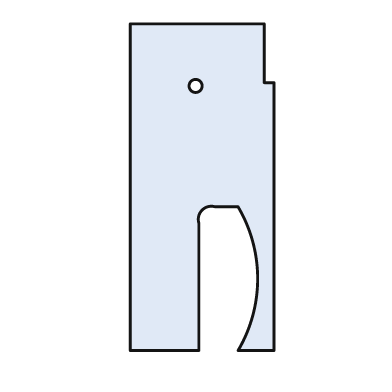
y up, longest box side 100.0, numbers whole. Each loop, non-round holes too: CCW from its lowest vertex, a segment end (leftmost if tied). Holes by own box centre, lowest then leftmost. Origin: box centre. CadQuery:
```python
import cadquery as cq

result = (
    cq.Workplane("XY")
    .moveTo(-22.0, -50.0)
    .lineTo(-1.0, -50.0)
    .lineTo(-1.0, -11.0)
    .threePointArc((0.0, -7.0), (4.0, -6.0))
    .lineTo(11.0, -6.0)
    .threePointArc((17.0, -28.0), (11.0, -50.0))
    .lineTo(22.0, -50.0)
    .lineTo(22.0, 32.0)
    .lineTo(19.0, 32.0)
    .lineTo(19.0, 50.0)
    .lineTo(-22.0, 50.0)
    .close()
    .moveTo(-2.0, 31.0)
    .circle(2.0)
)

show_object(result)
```